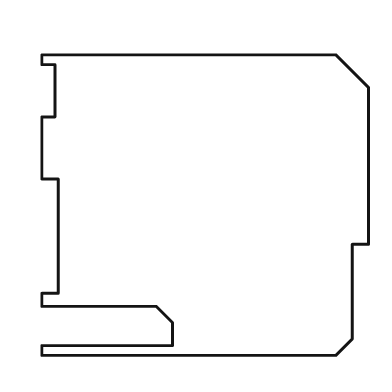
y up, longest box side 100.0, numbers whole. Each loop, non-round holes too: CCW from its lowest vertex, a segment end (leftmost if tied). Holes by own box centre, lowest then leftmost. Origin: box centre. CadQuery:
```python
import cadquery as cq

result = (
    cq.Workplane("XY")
    .moveTo(-50.0, -46.0)
    .lineTo(40.0, -46.0)
    .lineTo(45.0, -41.0)
    .lineTo(45.0, -12.0)
    .lineTo(50.0, -12.0)
    .lineTo(50.0, 36.0)
    .lineTo(40.0, 46.0)
    .lineTo(-50.0, 46.0)
    .lineTo(-50.0, 43.0)
    .lineTo(-46.0, 43.0)
    .lineTo(-46.0, 27.0)
    .lineTo(-50.0, 27.0)
    .lineTo(-50.0, 8.0)
    .lineTo(-45.0, 8.0)
    .lineTo(-45.0, -27.0)
    .lineTo(-50.0, -27.0)
    .lineTo(-50.0, -31.0)
    .lineTo(-15.0, -31.0)
    .lineTo(-10.0, -36.0)
    .lineTo(-10.0, -43.0)
    .lineTo(-50.0, -43.0)
    .close()
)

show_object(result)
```